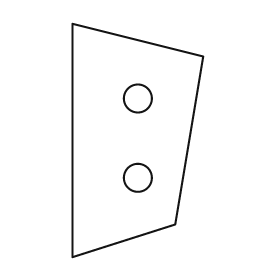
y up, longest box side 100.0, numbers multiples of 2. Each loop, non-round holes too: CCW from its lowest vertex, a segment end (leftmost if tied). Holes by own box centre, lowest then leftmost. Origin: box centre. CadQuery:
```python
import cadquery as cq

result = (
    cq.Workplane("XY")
    .moveTo(-28.0, -50.0)
    .lineTo(16.0, -36.0)
    .lineTo(28.0, 36.0)
    .lineTo(-28.0, 50.0)
    .close()
    .moveTo(0.0, -16.0)
    .circle(6.0)
    .moveTo(0.0, 18.0)
    .circle(6.0)
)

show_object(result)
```